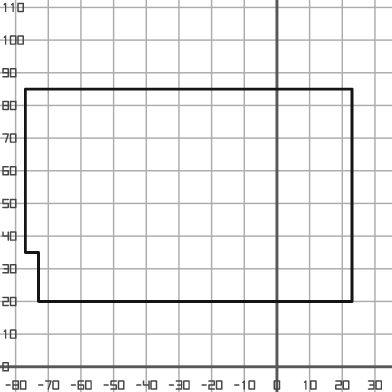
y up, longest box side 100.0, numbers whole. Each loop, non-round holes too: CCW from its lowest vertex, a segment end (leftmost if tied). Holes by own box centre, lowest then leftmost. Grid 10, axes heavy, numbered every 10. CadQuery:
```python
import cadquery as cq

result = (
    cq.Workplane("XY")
    .moveTo(-73.0, 20.0)
    .lineTo(23.0, 20.0)
    .lineTo(23.0, 85.0)
    .lineTo(-77.0, 85.0)
    .lineTo(-77.0, 35.0)
    .lineTo(-73.0, 35.0)
    .close()
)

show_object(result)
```